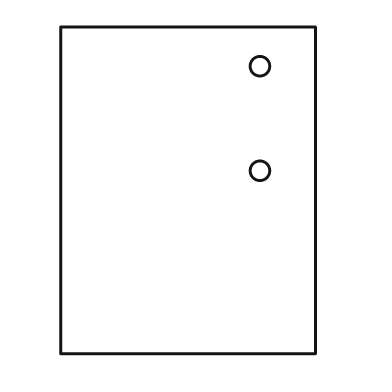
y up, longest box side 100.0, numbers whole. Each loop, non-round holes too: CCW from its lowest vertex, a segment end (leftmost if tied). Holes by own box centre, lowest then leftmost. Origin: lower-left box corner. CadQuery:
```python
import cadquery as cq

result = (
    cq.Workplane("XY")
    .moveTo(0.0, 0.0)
    .lineTo(78.0, 0.0)
    .lineTo(78.0, 100.0)
    .lineTo(0.0, 100.0)
    .close()
    .moveTo(61.0, 56.0)
    .circle(3.0)
    .moveTo(61.0, 88.0)
    .circle(3.0)
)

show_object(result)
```